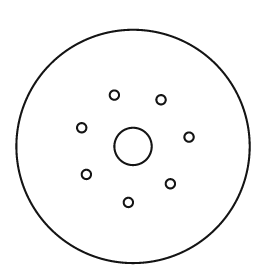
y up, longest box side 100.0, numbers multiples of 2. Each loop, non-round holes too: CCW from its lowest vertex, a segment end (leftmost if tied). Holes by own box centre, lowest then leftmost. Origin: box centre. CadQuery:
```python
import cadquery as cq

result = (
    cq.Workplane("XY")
    .moveTo(0.0, 0.0)
    .circle(50.0)
    .moveTo(-2.0, -24.0)
    .circle(2.0)
    .moveTo(16.0, -16.0)
    .circle(2.0)
    .moveTo(-20.0, -12.0)
    .circle(2.0)
    .moveTo(0.0, 0.0)
    .circle(8.0)
    .moveTo(24.0, 4.0)
    .circle(2.0)
    .moveTo(-22.0, 8.0)
    .circle(2.0)
    .moveTo(12.0, 20.0)
    .circle(2.0)
    .moveTo(-8.0, 22.0)
    .circle(2.0)
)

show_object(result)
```